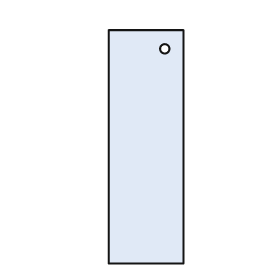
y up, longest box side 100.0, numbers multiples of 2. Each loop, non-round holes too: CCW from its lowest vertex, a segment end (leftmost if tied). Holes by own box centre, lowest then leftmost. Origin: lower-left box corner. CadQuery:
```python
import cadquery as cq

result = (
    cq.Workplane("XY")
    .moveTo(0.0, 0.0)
    .lineTo(32.0, 0.0)
    .lineTo(32.0, 100.0)
    .lineTo(0.0, 100.0)
    .close()
    .moveTo(24.0, 92.0)
    .circle(2.0)
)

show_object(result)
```